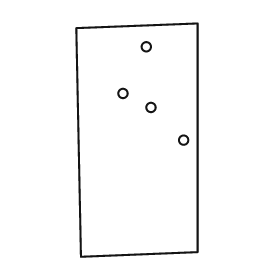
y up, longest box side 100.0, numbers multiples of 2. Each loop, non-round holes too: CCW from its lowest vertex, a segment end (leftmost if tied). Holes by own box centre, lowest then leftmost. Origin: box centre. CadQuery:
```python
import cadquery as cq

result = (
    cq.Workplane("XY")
    .moveTo(-24.0, -50.0)
    .lineTo(26.0, -48.0)
    .lineTo(26.0, 50.0)
    .lineTo(-26.0, 48.0)
    .close()
    .moveTo(20.0, 0.0)
    .circle(2.0)
    .moveTo(6.0, 14.0)
    .circle(2.0)
    .moveTo(-6.0, 20.0)
    .circle(2.0)
    .moveTo(4.0, 40.0)
    .circle(2.0)
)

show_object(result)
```